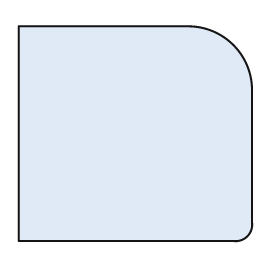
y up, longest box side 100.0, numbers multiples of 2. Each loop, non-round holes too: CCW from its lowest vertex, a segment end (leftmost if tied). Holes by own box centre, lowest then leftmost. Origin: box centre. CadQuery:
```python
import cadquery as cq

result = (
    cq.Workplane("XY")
    .moveTo(-50.0, -46.0)
    .lineTo(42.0, -46.0)
    .threePointArc((48.0, -44.0), (50.0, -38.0))
    .lineTo(50.0, 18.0)
    .threePointArc((42.0, 38.0), (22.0, 46.0))
    .lineTo(-50.0, 46.0)
    .close()
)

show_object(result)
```